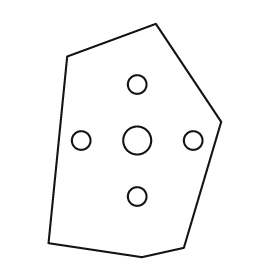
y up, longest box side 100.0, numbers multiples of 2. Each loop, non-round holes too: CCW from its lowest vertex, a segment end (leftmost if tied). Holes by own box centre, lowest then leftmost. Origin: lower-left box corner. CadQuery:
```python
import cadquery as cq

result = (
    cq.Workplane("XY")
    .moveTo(40.0, 0.0)
    .lineTo(58.0, 4.0)
    .lineTo(74.0, 58.0)
    .lineTo(46.0, 100.0)
    .lineTo(8.0, 86.0)
    .lineTo(0.0, 6.0)
    .close()
    .moveTo(38.0, 26.0)
    .circle(4.0)
    .moveTo(14.0, 50.0)
    .circle(4.0)
    .moveTo(38.0, 50.0)
    .circle(6.0)
    .moveTo(62.0, 50.0)
    .circle(4.0)
    .moveTo(38.0, 74.0)
    .circle(4.0)
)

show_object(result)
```